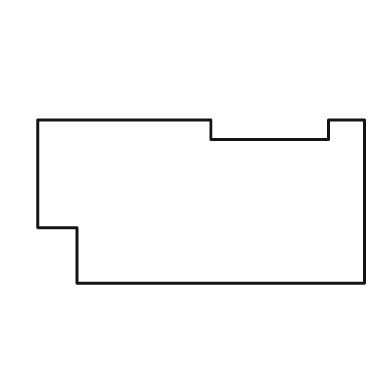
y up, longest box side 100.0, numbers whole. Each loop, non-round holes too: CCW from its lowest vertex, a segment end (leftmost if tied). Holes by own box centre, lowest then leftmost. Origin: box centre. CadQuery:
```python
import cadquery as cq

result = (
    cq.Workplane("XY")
    .moveTo(-38.0, -25.0)
    .lineTo(50.0, -25.0)
    .lineTo(50.0, 25.0)
    .lineTo(39.0, 25.0)
    .lineTo(39.0, 19.0)
    .lineTo(3.0, 19.0)
    .lineTo(3.0, 25.0)
    .lineTo(-50.0, 25.0)
    .lineTo(-50.0, -8.0)
    .lineTo(-38.0, -8.0)
    .close()
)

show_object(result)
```